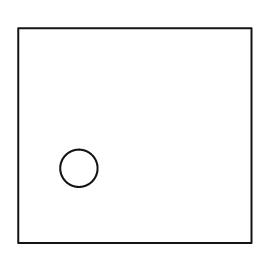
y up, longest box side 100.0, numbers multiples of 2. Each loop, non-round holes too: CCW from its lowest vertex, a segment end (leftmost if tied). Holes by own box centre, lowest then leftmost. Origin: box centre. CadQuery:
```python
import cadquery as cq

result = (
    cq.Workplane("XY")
    .moveTo(-50.0, -46.0)
    .lineTo(50.0, -46.0)
    .lineTo(50.0, 46.0)
    .lineTo(-50.0, 46.0)
    .close()
    .moveTo(-24.0, -14.0)
    .circle(8.0)
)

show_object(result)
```